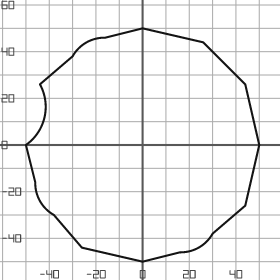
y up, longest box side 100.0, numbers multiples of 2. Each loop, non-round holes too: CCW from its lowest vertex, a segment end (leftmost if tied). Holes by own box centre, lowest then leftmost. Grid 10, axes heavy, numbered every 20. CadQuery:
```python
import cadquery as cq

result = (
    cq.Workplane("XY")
    .moveTo(0.0, -50.0)
    .lineTo(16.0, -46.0)
    .threePointArc((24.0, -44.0), (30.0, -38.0))
    .lineTo(44.0, -26.0)
    .lineTo(50.0, 0.0)
    .lineTo(44.0, 26.0)
    .lineTo(26.0, 44.0)
    .lineTo(0.0, 50.0)
    .lineTo(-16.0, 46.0)
    .threePointArc((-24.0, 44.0), (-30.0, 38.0))
    .lineTo(-44.0, 26.0)
    .threePointArc((-42.0, 12.0), (-50.0, 0.0))
    .lineTo(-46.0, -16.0)
    .threePointArc((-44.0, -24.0), (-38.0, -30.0))
    .lineTo(-26.0, -44.0)
    .close()
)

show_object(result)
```